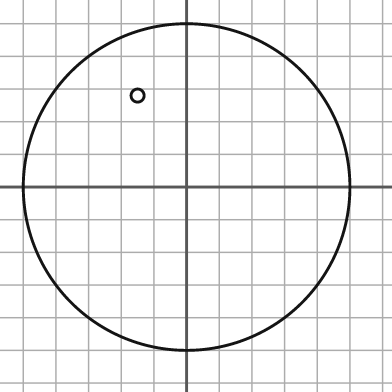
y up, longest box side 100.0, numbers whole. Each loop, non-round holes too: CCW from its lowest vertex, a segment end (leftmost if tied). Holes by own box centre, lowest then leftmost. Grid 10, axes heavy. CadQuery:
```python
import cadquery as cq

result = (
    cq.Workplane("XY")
    .moveTo(0.0, 0.0)
    .circle(50.0)
    .moveTo(-15.0, 28.0)
    .circle(2.0)
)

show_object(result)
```